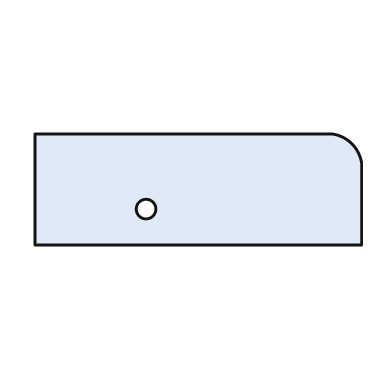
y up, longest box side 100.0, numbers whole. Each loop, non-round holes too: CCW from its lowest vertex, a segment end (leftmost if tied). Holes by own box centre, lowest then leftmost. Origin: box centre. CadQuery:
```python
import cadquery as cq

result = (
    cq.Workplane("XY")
    .moveTo(-50.0, -17.0)
    .lineTo(50.0, -17.0)
    .lineTo(50.0, 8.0)
    .threePointArc((47.0, 14.0), (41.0, 17.0))
    .lineTo(-50.0, 17.0)
    .close()
    .moveTo(-16.0, -6.0)
    .circle(3.0)
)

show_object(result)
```